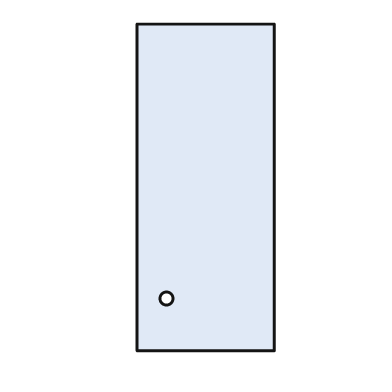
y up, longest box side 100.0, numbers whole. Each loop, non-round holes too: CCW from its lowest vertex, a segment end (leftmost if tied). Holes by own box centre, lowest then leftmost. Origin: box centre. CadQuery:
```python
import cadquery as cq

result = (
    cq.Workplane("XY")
    .moveTo(-21.0, -50.0)
    .lineTo(21.0, -50.0)
    .lineTo(21.0, 50.0)
    .lineTo(-21.0, 50.0)
    .close()
    .moveTo(-12.0, -34.0)
    .circle(2.0)
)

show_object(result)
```